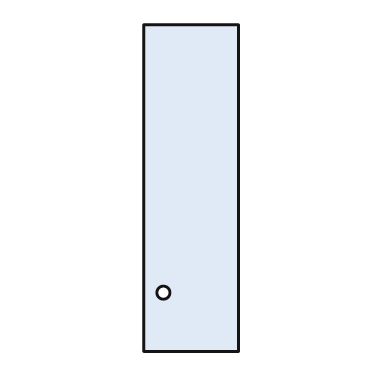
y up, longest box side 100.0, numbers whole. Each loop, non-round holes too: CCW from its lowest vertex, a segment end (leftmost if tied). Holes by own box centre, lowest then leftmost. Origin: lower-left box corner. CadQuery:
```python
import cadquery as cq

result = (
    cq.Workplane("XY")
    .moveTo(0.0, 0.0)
    .lineTo(29.0, 0.0)
    .lineTo(29.0, 100.0)
    .lineTo(0.0, 100.0)
    .close()
    .moveTo(6.0, 18.0)
    .circle(2.0)
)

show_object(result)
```